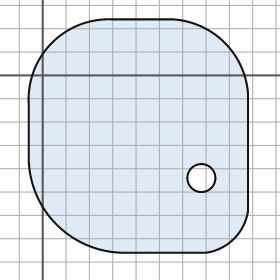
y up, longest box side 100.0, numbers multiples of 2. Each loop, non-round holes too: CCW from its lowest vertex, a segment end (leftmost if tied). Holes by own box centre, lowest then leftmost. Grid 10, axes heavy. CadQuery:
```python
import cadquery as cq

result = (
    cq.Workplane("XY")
    .moveTo(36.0, -76.0)
    .lineTo(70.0, -76.0)
    .threePointArc((82.0, -70.0), (88.0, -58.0))
    .lineTo(88.0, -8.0)
    .threePointArc((78.0, 14.0), (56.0, 24.0))
    .lineTo(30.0, 24.0)
    .threePointArc((4.0, 14.0), (-6.0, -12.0))
    .lineTo(-6.0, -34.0)
    .threePointArc((6.0, -64.0), (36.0, -76.0))
    .close()
    .moveTo(68.0, -44.0)
    .circle(6.0)
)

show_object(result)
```